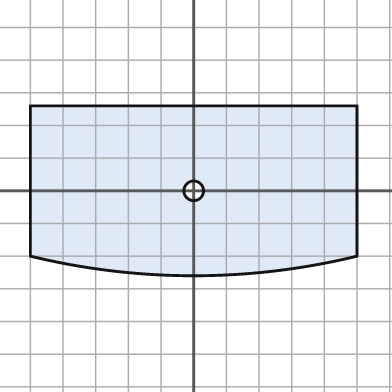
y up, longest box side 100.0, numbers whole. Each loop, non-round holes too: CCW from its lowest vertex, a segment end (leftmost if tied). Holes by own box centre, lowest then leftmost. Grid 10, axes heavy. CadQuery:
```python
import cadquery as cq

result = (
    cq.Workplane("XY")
    .moveTo(-50.0, -20.0)
    .threePointArc((0.0, -26.0), (50.0, -20.0))
    .lineTo(50.0, 26.0)
    .lineTo(-50.0, 26.0)
    .close()
    .moveTo(0.0, 0.0)
    .circle(3.0)
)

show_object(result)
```